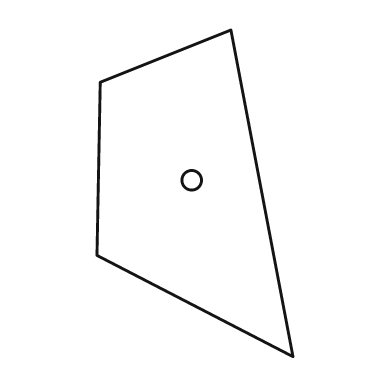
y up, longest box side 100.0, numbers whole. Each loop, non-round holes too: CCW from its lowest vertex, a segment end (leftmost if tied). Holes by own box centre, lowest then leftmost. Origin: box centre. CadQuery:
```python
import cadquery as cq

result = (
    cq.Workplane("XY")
    .moveTo(30.0, -50.0)
    .lineTo(11.0, 50.0)
    .lineTo(-29.0, 34.0)
    .lineTo(-30.0, -19.0)
    .close()
    .moveTo(-1.0, 4.0)
    .circle(3.0)
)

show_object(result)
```